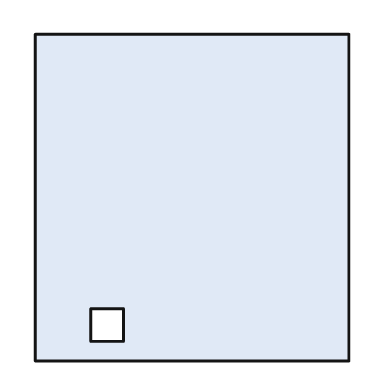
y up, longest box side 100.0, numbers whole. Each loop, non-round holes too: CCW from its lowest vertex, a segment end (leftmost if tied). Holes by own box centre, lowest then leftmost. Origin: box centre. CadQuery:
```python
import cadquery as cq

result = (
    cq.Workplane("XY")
    .moveTo(-48.0, -50.0)
    .lineTo(48.0, -50.0)
    .lineTo(48.0, 50.0)
    .lineTo(-48.0, 50.0)
    .close()
    .moveTo(-31.0, -44.0)
    .lineTo(-21.0, -44.0)
    .lineTo(-21.0, -34.0)
    .lineTo(-31.0, -34.0)
    .close()
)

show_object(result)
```